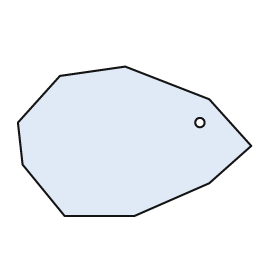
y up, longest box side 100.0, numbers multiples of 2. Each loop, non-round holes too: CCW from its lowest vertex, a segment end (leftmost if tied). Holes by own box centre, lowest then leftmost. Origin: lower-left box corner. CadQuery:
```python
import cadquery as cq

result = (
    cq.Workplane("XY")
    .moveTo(20.0, 0.0)
    .lineTo(50.0, 0.0)
    .lineTo(82.0, 14.0)
    .lineTo(100.0, 30.0)
    .lineTo(82.0, 50.0)
    .lineTo(46.0, 64.0)
    .lineTo(18.0, 60.0)
    .lineTo(0.0, 40.0)
    .lineTo(2.0, 22.0)
    .close()
    .moveTo(78.0, 40.0)
    .circle(2.0)
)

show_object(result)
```